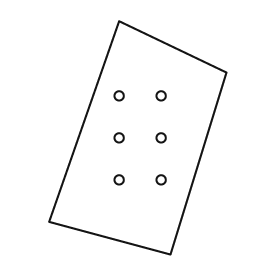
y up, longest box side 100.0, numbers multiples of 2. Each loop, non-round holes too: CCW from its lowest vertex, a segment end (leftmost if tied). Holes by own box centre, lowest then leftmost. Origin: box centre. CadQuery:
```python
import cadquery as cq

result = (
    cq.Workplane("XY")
    .moveTo(14.0, -50.0)
    .lineTo(38.0, 28.0)
    .lineTo(-8.0, 50.0)
    .lineTo(-38.0, -36.0)
    .close()
    .moveTo(-8.0, -18.0)
    .circle(2.0)
    .moveTo(10.0, -18.0)
    .circle(2.0)
    .moveTo(-8.0, 0.0)
    .circle(2.0)
    .moveTo(10.0, 0.0)
    .circle(2.0)
    .moveTo(-8.0, 18.0)
    .circle(2.0)
    .moveTo(10.0, 18.0)
    .circle(2.0)
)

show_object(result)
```